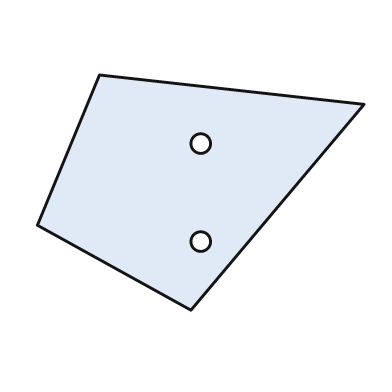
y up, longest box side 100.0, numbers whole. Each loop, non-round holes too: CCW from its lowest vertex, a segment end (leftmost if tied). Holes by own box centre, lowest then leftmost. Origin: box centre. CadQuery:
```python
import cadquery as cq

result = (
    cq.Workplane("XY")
    .moveTo(-3.0, -36.0)
    .lineTo(50.0, 27.0)
    .lineTo(-31.0, 36.0)
    .lineTo(-50.0, -10.0)
    .close()
    .moveTo(0.0, -15.0)
    .circle(3.0)
    .moveTo(0.0, 15.0)
    .circle(3.0)
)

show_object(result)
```